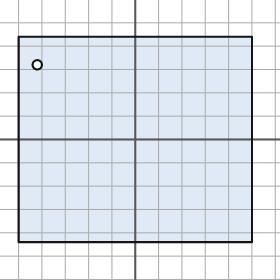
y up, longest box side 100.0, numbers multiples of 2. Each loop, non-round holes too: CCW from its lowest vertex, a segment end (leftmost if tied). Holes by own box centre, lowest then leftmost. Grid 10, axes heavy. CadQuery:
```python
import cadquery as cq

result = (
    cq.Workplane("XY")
    .moveTo(-50.0, -44.0)
    .lineTo(50.0, -44.0)
    .lineTo(50.0, 44.0)
    .lineTo(-50.0, 44.0)
    .close()
    .moveTo(-42.0, 32.0)
    .circle(2.0)
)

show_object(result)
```